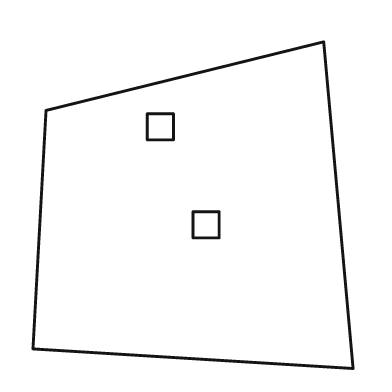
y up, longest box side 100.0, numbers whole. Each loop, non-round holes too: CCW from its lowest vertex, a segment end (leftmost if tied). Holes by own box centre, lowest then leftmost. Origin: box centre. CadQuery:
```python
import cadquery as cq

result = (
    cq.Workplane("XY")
    .moveTo(49.0, -50.0)
    .lineTo(40.0, 50.0)
    .lineTo(-45.0, 29.0)
    .lineTo(-49.0, -44.0)
    .close()
    .moveTo(0.0, -10.0)
    .lineTo(8.0, -10.0)
    .lineTo(8.0, -2.0)
    .lineTo(0.0, -2.0)
    .close()
    .moveTo(-14.0, 20.0)
    .lineTo(-6.0, 20.0)
    .lineTo(-6.0, 28.0)
    .lineTo(-14.0, 28.0)
    .close()
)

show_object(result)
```